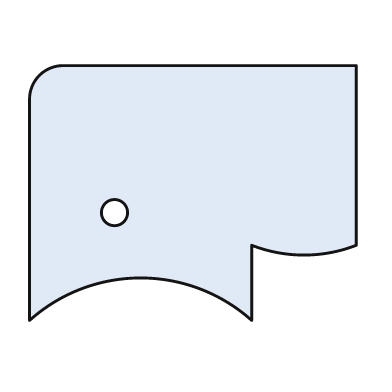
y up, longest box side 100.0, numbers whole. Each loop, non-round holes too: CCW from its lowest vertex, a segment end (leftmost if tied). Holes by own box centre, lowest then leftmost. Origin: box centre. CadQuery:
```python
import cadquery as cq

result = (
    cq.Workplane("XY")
    .moveTo(-50.0, -39.0)
    .threePointArc((-16.0, -26.0), (18.0, -39.0))
    .lineTo(18.0, -16.0)
    .threePointArc((34.0, -19.0), (50.0, -16.0))
    .lineTo(50.0, 39.0)
    .lineTo(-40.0, 39.0)
    .threePointArc((-47.0, 36.0), (-50.0, 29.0))
    .close()
    .moveTo(-24.0, -6.0)
    .circle(4.0)
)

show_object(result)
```